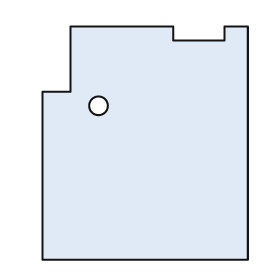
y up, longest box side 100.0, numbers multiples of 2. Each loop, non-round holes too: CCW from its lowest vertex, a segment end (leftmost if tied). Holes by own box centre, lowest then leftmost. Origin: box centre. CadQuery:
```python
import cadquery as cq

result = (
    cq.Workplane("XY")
    .moveTo(-44.0, -50.0)
    .lineTo(44.0, -50.0)
    .lineTo(44.0, 50.0)
    .lineTo(34.0, 50.0)
    .lineTo(34.0, 44.0)
    .lineTo(12.0, 44.0)
    .lineTo(12.0, 50.0)
    .lineTo(-32.0, 50.0)
    .lineTo(-32.0, 22.0)
    .lineTo(-44.0, 22.0)
    .close()
    .moveTo(-20.0, 16.0)
    .circle(4.0)
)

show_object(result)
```